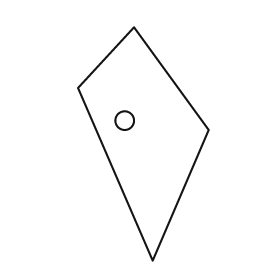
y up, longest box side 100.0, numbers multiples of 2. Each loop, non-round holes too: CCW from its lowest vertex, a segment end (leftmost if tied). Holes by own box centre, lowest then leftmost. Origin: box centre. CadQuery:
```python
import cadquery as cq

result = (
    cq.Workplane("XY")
    .moveTo(4.0, -50.0)
    .lineTo(28.0, 6.0)
    .lineTo(-4.0, 50.0)
    .lineTo(-28.0, 24.0)
    .close()
    .moveTo(-8.0, 10.0)
    .circle(4.0)
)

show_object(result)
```